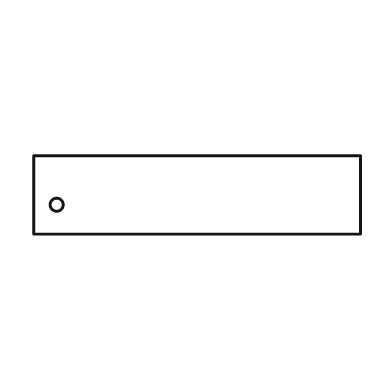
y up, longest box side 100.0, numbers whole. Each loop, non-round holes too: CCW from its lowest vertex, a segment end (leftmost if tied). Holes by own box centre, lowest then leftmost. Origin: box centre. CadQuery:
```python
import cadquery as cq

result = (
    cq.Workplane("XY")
    .moveTo(-50.0, -12.0)
    .lineTo(50.0, -12.0)
    .lineTo(50.0, 12.0)
    .lineTo(-50.0, 12.0)
    .close()
    .moveTo(-43.0, -3.0)
    .circle(2.0)
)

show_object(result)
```